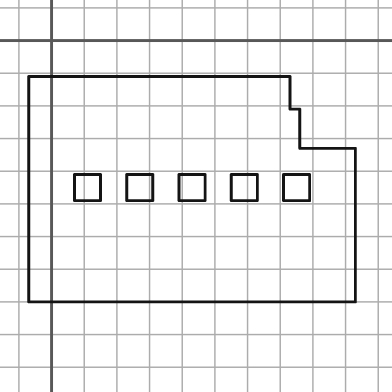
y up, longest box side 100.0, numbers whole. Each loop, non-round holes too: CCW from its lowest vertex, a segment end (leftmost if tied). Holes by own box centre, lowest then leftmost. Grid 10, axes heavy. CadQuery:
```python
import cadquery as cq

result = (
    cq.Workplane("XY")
    .moveTo(-7.0, -80.0)
    .lineTo(93.0, -80.0)
    .lineTo(93.0, -33.0)
    .lineTo(76.0, -33.0)
    .lineTo(76.0, -21.0)
    .lineTo(73.0, -21.0)
    .lineTo(73.0, -11.0)
    .lineTo(-7.0, -11.0)
    .close()
    .moveTo(7.0, -49.0)
    .lineTo(15.0, -49.0)
    .lineTo(15.0, -41.0)
    .lineTo(7.0, -41.0)
    .close()
    .moveTo(23.0, -49.0)
    .lineTo(31.0, -49.0)
    .lineTo(31.0, -41.0)
    .lineTo(23.0, -41.0)
    .close()
    .moveTo(39.0, -49.0)
    .lineTo(47.0, -49.0)
    .lineTo(47.0, -41.0)
    .lineTo(39.0, -41.0)
    .close()
    .moveTo(55.0, -49.0)
    .lineTo(63.0, -49.0)
    .lineTo(63.0, -41.0)
    .lineTo(55.0, -41.0)
    .close()
    .moveTo(71.0, -49.0)
    .lineTo(79.0, -49.0)
    .lineTo(79.0, -41.0)
    .lineTo(71.0, -41.0)
    .close()
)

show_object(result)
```